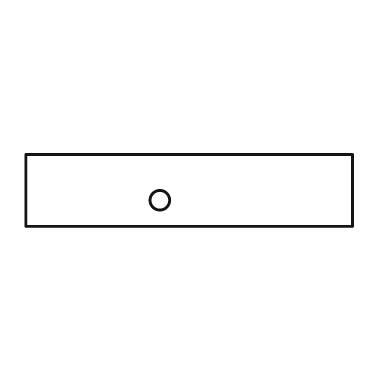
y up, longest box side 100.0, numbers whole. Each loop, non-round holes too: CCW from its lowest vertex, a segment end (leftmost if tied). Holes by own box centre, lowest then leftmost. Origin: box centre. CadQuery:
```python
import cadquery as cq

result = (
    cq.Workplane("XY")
    .moveTo(-50.0, -11.0)
    .lineTo(50.0, -11.0)
    .lineTo(50.0, 11.0)
    .lineTo(-50.0, 11.0)
    .close()
    .moveTo(-9.0, -3.0)
    .circle(3.0)
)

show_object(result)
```